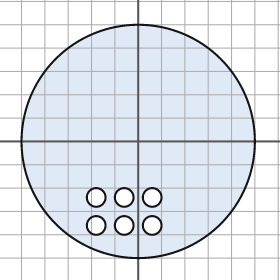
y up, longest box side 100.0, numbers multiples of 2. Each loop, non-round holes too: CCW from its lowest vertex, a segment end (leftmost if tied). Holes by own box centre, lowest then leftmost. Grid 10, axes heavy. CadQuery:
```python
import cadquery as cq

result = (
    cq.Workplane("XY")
    .moveTo(0.0, 0.0)
    .circle(50.0)
    .moveTo(-18.0, -36.0)
    .circle(4.0)
    .moveTo(-6.0, -36.0)
    .circle(4.0)
    .moveTo(6.0, -36.0)
    .circle(4.0)
    .moveTo(-18.0, -24.0)
    .circle(4.0)
    .moveTo(-6.0, -24.0)
    .circle(4.0)
    .moveTo(6.0, -24.0)
    .circle(4.0)
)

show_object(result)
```